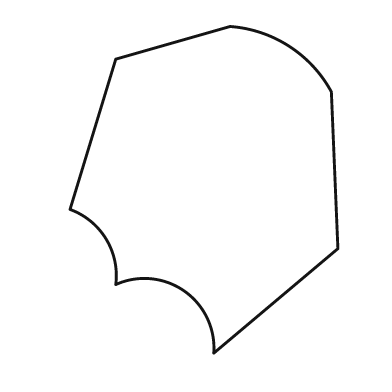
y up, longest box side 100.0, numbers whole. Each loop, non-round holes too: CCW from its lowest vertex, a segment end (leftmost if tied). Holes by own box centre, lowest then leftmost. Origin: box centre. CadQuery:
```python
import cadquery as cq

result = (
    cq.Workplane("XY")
    .moveTo(3.0, -50.0)
    .lineTo(41.0, -18.0)
    .lineTo(39.0, 30.0)
    .threePointArc((26.0, 44.0), (8.0, 50.0))
    .lineTo(-27.0, 40.0)
    .lineTo(-41.0, -6.0)
    .threePointArc((-30.0, -15.0), (-27.0, -29.0))
    .threePointArc((-6.0, -31.0), (3.0, -50.0))
    .close()
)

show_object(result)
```